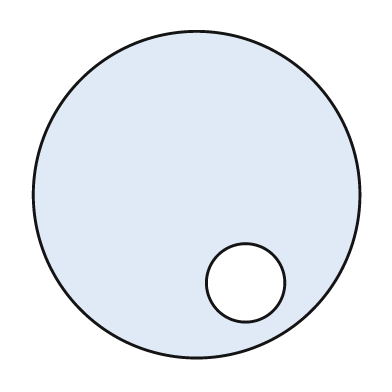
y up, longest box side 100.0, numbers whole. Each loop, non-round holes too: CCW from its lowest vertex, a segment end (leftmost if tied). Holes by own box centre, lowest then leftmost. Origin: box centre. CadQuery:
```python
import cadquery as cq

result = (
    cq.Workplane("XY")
    .moveTo(0.0, 0.0)
    .circle(50.0)
    .moveTo(15.0, -27.0)
    .circle(12.0)
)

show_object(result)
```